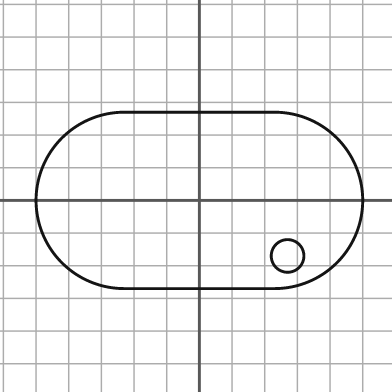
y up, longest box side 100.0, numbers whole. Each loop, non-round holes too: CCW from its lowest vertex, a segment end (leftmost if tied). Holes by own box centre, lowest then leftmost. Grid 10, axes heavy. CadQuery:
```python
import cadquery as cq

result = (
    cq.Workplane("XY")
    .moveTo(-23.0, -27.0)
    .lineTo(23.0, -27.0)
    .threePointArc((50.0, 0.0), (23.0, 27.0))
    .lineTo(-23.0, 27.0)
    .threePointArc((-50.0, 0.0), (-23.0, -27.0))
    .close()
    .moveTo(27.0, -17.0)
    .circle(5.0)
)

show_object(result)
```